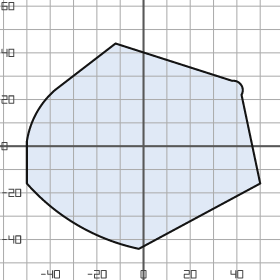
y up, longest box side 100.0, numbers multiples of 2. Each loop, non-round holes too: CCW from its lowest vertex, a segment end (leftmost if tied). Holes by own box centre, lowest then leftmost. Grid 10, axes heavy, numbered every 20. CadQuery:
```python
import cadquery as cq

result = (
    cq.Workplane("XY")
    .moveTo(-2.0, -44.0)
    .lineTo(50.0, -16.0)
    .lineTo(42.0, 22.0)
    .threePointArc((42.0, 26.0), (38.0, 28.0))
    .lineTo(-12.0, 44.0)
    .lineTo(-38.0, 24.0)
    .threePointArc((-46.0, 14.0), (-50.0, 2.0))
    .lineTo(-50.0, -16.0)
    .threePointArc((-28.0, -34.0), (-2.0, -44.0))
    .close()
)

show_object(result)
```